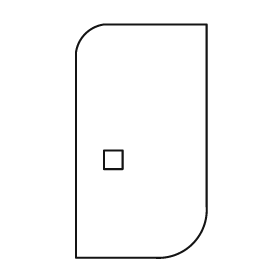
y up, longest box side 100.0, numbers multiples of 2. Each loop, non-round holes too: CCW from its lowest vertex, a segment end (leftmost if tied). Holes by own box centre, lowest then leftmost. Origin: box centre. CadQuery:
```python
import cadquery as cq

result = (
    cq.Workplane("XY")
    .moveTo(-28.0, -50.0)
    .lineTo(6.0, -50.0)
    .threePointArc((22.0, -44.0), (28.0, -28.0))
    .lineTo(28.0, 50.0)
    .lineTo(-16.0, 50.0)
    .threePointArc((-24.0, 46.0), (-28.0, 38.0))
    .close()
    .moveTo(-16.0, -12.0)
    .lineTo(-8.0, -12.0)
    .lineTo(-8.0, -4.0)
    .lineTo(-16.0, -4.0)
    .close()
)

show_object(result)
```